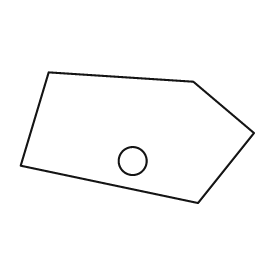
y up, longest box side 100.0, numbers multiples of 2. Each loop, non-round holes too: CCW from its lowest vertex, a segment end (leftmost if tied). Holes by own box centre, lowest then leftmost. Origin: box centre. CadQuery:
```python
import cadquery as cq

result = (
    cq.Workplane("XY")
    .moveTo(26.0, -28.0)
    .lineTo(50.0, 2.0)
    .lineTo(24.0, 24.0)
    .lineTo(-38.0, 28.0)
    .lineTo(-50.0, -12.0)
    .close()
    .moveTo(-2.0, -10.0)
    .circle(6.0)
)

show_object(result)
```